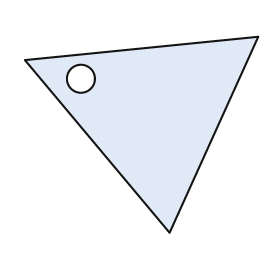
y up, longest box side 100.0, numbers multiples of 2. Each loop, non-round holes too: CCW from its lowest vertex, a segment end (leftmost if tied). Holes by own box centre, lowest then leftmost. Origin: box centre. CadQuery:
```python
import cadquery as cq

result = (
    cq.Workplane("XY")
    .moveTo(12.0, -42.0)
    .lineTo(50.0, 42.0)
    .lineTo(-50.0, 32.0)
    .close()
    .moveTo(-26.0, 24.0)
    .circle(6.0)
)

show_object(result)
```